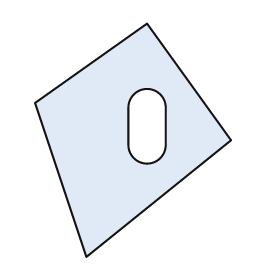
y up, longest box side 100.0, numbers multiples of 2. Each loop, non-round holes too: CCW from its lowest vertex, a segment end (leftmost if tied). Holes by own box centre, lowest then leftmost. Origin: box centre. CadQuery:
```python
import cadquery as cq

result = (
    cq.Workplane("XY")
    .moveTo(-20.0, -50.0)
    .lineTo(42.0, 0.0)
    .lineTo(6.0, 50.0)
    .lineTo(-42.0, 16.0)
    .close()
    .moveTo(-2.0, -2.0)
    .threePointArc((6.0, -10.0), (14.0, -2.0))
    .lineTo(14.0, 14.0)
    .threePointArc((6.0, 22.0), (-2.0, 14.0))
    .close()
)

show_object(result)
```